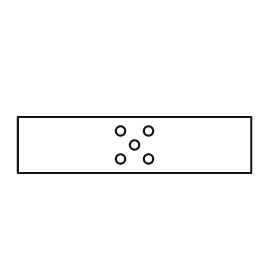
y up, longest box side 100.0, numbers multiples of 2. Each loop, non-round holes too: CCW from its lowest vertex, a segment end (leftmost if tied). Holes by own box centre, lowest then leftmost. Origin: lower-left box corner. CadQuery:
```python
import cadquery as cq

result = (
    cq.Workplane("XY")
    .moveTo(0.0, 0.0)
    .lineTo(100.0, 0.0)
    .lineTo(100.0, 24.0)
    .lineTo(0.0, 24.0)
    .close()
    .moveTo(44.0, 6.0)
    .circle(2.0)
    .moveTo(56.0, 6.0)
    .circle(2.0)
    .moveTo(50.0, 12.0)
    .circle(2.0)
    .moveTo(44.0, 18.0)
    .circle(2.0)
    .moveTo(56.0, 18.0)
    .circle(2.0)
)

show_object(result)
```